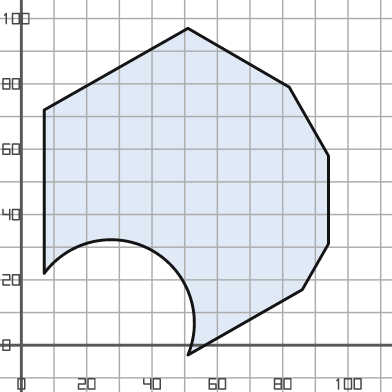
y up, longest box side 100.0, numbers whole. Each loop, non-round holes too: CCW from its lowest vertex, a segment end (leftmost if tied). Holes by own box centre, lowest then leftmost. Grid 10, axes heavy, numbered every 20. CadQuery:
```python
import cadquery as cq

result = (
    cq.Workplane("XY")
    .moveTo(51.0, -3.0)
    .lineTo(86.0, 17.0)
    .lineTo(94.0, 31.0)
    .lineTo(94.0, 58.0)
    .lineTo(82.0, 79.0)
    .lineTo(51.0, 97.0)
    .lineTo(7.0, 72.0)
    .lineTo(7.0, 22.0)
    .threePointArc((40.0, 29.0), (51.0, -3.0))
    .close()
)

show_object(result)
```